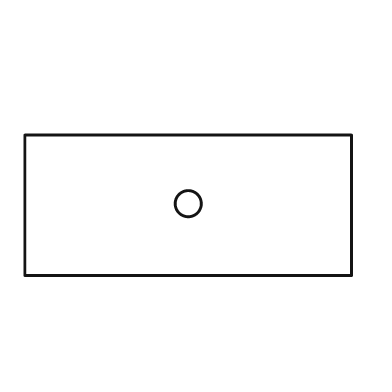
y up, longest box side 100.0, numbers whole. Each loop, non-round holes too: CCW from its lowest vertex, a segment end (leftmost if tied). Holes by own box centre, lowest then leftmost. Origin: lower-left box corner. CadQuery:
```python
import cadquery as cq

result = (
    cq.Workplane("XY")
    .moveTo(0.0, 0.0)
    .lineTo(100.0, 0.0)
    .lineTo(100.0, 43.0)
    .lineTo(0.0, 43.0)
    .close()
    .moveTo(50.0, 22.0)
    .circle(4.0)
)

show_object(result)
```